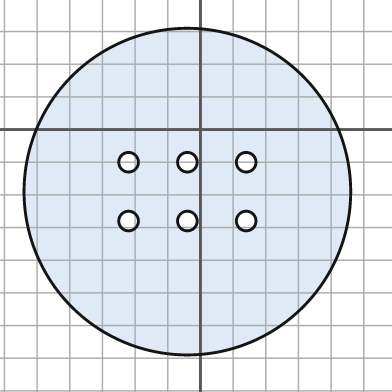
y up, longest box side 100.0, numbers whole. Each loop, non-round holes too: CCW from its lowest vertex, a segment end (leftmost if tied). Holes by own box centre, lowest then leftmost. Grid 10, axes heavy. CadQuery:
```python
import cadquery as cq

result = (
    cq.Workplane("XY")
    .moveTo(-4.0, -19.0)
    .circle(50.0)
    .moveTo(-22.0, -28.0)
    .circle(3.0)
    .moveTo(-4.0, -28.0)
    .circle(3.0)
    .moveTo(14.0, -28.0)
    .circle(3.0)
    .moveTo(-22.0, -10.0)
    .circle(3.0)
    .moveTo(-4.0, -10.0)
    .circle(3.0)
    .moveTo(14.0, -10.0)
    .circle(3.0)
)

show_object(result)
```